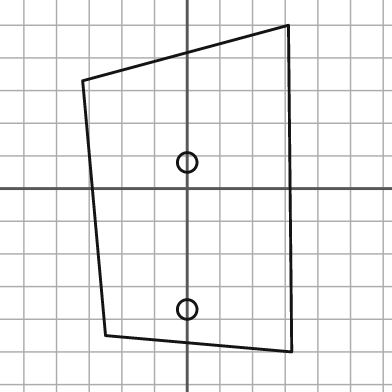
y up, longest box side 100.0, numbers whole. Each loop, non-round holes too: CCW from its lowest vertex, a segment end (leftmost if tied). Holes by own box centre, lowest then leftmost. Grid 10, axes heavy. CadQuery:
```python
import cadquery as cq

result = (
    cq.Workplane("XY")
    .moveTo(32.0, -50.0)
    .lineTo(31.0, 50.0)
    .lineTo(-32.0, 33.0)
    .lineTo(-25.0, -45.0)
    .close()
    .moveTo(0.0, -37.0)
    .circle(3.0)
    .moveTo(0.0, 8.0)
    .circle(3.0)
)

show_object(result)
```